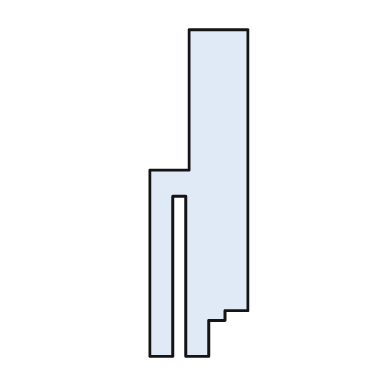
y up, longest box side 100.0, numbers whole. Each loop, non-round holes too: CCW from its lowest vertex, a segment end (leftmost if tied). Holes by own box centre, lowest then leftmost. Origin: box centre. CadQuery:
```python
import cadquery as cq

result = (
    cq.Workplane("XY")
    .moveTo(-15.0, -50.0)
    .lineTo(-8.0, -50.0)
    .lineTo(-8.0, -1.0)
    .lineTo(-4.0, -1.0)
    .lineTo(-4.0, -50.0)
    .lineTo(3.0, -50.0)
    .lineTo(3.0, -39.0)
    .lineTo(8.0, -39.0)
    .lineTo(8.0, -36.0)
    .lineTo(15.0, -36.0)
    .lineTo(15.0, 50.0)
    .lineTo(-3.0, 50.0)
    .lineTo(-3.0, 7.0)
    .lineTo(-15.0, 7.0)
    .close()
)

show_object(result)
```